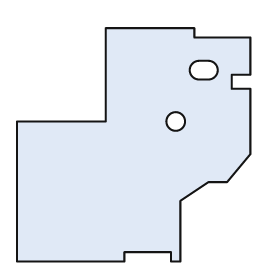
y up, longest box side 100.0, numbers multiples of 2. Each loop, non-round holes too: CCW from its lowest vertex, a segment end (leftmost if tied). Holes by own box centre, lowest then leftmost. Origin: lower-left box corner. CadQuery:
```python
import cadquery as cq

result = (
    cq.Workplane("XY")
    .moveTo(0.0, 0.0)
    .lineTo(46.0, 0.0)
    .lineTo(46.0, 4.0)
    .lineTo(66.0, 4.0)
    .lineTo(66.0, 0.0)
    .lineTo(70.0, 0.0)
    .lineTo(70.0, 26.0)
    .lineTo(82.0, 34.0)
    .lineTo(90.0, 34.0)
    .lineTo(100.0, 46.0)
    .lineTo(100.0, 74.0)
    .lineTo(92.0, 74.0)
    .lineTo(92.0, 80.0)
    .lineTo(100.0, 80.0)
    .lineTo(100.0, 96.0)
    .lineTo(76.0, 96.0)
    .lineTo(76.0, 100.0)
    .lineTo(38.0, 100.0)
    .lineTo(38.0, 60.0)
    .lineTo(0.0, 60.0)
    .close()
    .moveTo(68.0, 60.0)
    .circle(4.0)
    .moveTo(78.0, 78.0)
    .lineTo(82.0, 78.0)
    .threePointArc((86.0, 82.0), (82.0, 86.0))
    .lineTo(78.0, 86.0)
    .threePointArc((74.0, 82.0), (78.0, 78.0))
    .close()
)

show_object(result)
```